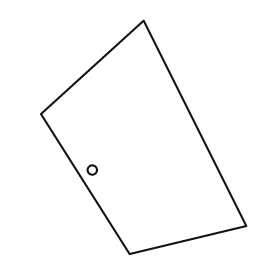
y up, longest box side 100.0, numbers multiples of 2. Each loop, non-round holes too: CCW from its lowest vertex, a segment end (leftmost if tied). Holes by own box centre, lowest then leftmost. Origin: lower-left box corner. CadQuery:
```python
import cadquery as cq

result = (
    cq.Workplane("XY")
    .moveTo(38.0, 0.0)
    .lineTo(88.0, 12.0)
    .lineTo(44.0, 100.0)
    .lineTo(0.0, 60.0)
    .close()
    .moveTo(22.0, 36.0)
    .circle(2.0)
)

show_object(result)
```